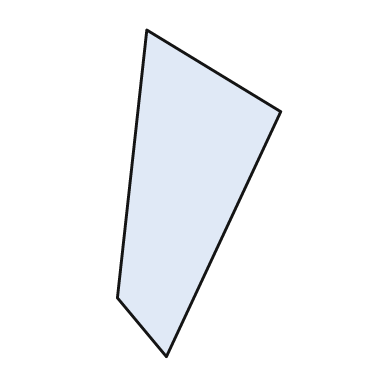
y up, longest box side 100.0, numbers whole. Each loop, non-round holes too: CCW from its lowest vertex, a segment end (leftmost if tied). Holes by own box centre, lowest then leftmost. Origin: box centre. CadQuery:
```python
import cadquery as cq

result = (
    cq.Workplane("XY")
    .moveTo(-10.0, -50.0)
    .lineTo(25.0, 25.0)
    .lineTo(-16.0, 50.0)
    .lineTo(-25.0, -32.0)
    .close()
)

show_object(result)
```